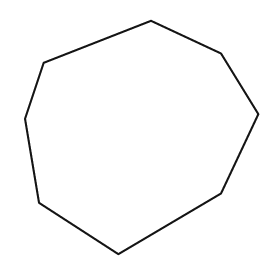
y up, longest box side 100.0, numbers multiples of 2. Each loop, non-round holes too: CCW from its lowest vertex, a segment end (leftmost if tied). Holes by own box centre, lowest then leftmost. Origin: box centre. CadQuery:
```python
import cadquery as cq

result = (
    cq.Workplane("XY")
    .moveTo(-10.0, -50.0)
    .lineTo(34.0, -24.0)
    .lineTo(50.0, 10.0)
    .lineTo(34.0, 36.0)
    .lineTo(4.0, 50.0)
    .lineTo(-42.0, 32.0)
    .lineTo(-50.0, 8.0)
    .lineTo(-44.0, -28.0)
    .close()
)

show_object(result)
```